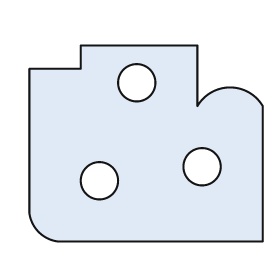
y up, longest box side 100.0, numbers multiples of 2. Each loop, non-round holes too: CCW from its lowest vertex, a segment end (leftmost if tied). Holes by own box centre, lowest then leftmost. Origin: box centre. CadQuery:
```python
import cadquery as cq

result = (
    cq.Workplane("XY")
    .moveTo(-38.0, -42.0)
    .lineTo(50.0, -42.0)
    .lineTo(50.0, 16.0)
    .threePointArc((36.0, 24.0), (22.0, 16.0))
    .lineTo(22.0, 42.0)
    .lineTo(-28.0, 42.0)
    .lineTo(-28.0, 32.0)
    .lineTo(-50.0, 32.0)
    .lineTo(-50.0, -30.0)
    .threePointArc((-46.0, -38.0), (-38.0, -42.0))
    .close()
    .moveTo(-20.0, -16.0)
    .circle(8.0)
    .moveTo(24.0, -10.0)
    .circle(8.0)
    .moveTo(-4.0, 26.0)
    .circle(8.0)
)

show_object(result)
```